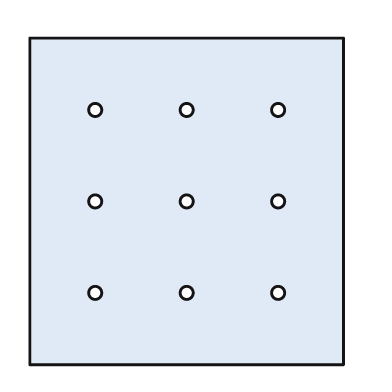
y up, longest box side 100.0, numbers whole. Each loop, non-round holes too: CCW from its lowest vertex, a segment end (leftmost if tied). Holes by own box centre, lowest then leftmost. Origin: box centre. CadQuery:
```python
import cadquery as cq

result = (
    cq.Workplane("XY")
    .moveTo(-48.0, -50.0)
    .lineTo(48.0, -50.0)
    .lineTo(48.0, 50.0)
    .lineTo(-48.0, 50.0)
    .close()
    .moveTo(-28.0, -28.0)
    .circle(2.0)
    .moveTo(0.0, -28.0)
    .circle(2.0)
    .moveTo(28.0, -28.0)
    .circle(2.0)
    .moveTo(-28.0, 0.0)
    .circle(2.0)
    .moveTo(0.0, 0.0)
    .circle(2.0)
    .moveTo(28.0, 0.0)
    .circle(2.0)
    .moveTo(-28.0, 28.0)
    .circle(2.0)
    .moveTo(0.0, 28.0)
    .circle(2.0)
    .moveTo(28.0, 28.0)
    .circle(2.0)
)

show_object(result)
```